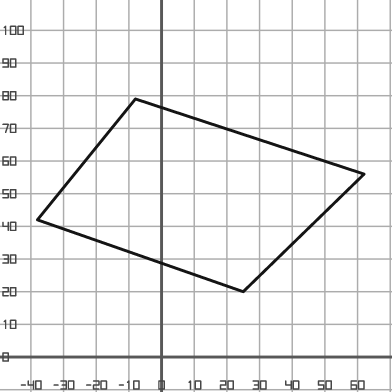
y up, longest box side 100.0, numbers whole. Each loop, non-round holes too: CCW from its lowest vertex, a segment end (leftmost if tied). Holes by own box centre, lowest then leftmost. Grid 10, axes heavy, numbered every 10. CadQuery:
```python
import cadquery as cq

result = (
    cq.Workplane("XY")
    .moveTo(25.0, 20.0)
    .lineTo(62.0, 56.0)
    .lineTo(-8.0, 79.0)
    .lineTo(-38.0, 42.0)
    .close()
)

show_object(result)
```